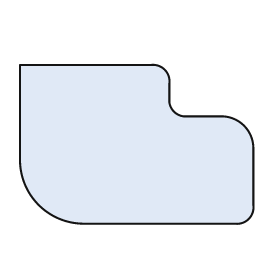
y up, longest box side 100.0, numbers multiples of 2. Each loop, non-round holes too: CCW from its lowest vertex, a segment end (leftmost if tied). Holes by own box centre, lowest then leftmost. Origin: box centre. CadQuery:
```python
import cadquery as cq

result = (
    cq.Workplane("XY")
    .moveTo(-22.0, -34.0)
    .lineTo(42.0, -34.0)
    .threePointArc((48.0, -32.0), (50.0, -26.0))
    .lineTo(50.0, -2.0)
    .threePointArc((46.0, 8.0), (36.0, 12.0))
    .lineTo(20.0, 12.0)
    .threePointArc((16.0, 14.0), (14.0, 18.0))
    .lineTo(14.0, 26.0)
    .threePointArc((12.0, 32.0), (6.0, 34.0))
    .lineTo(-50.0, 34.0)
    .lineTo(-50.0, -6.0)
    .threePointArc((-42.0, -26.0), (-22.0, -34.0))
    .close()
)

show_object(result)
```